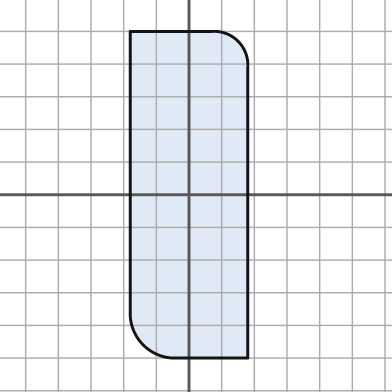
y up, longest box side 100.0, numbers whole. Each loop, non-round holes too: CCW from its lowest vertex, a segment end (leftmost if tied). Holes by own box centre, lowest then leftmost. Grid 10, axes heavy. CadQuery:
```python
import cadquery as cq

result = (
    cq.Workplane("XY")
    .moveTo(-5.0, -50.0)
    .lineTo(18.0, -50.0)
    .lineTo(18.0, 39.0)
    .threePointArc((15.0, 47.0), (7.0, 50.0))
    .lineTo(-18.0, 50.0)
    .lineTo(-18.0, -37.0)
    .threePointArc((-14.0, -46.0), (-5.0, -50.0))
    .close()
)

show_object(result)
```